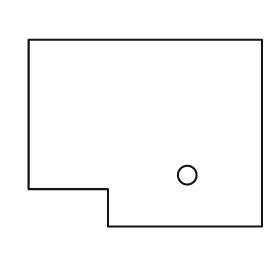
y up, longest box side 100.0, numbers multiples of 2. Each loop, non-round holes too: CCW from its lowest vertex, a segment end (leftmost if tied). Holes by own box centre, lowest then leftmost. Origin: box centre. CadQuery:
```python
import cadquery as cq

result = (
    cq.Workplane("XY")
    .moveTo(-16.0, -40.0)
    .lineTo(50.0, -40.0)
    .lineTo(50.0, 40.0)
    .lineTo(-50.0, 40.0)
    .lineTo(-50.0, -24.0)
    .lineTo(-16.0, -24.0)
    .close()
    .moveTo(18.0, -18.0)
    .circle(4.0)
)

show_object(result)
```